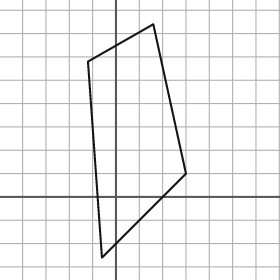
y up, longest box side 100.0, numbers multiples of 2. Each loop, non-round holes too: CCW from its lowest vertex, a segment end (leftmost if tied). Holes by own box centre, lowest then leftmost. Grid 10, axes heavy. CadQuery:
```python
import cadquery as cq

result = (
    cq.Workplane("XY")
    .moveTo(-6.0, -26.0)
    .lineTo(30.0, 10.0)
    .lineTo(16.0, 74.0)
    .lineTo(-12.0, 58.0)
    .close()
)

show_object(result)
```